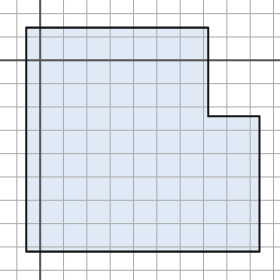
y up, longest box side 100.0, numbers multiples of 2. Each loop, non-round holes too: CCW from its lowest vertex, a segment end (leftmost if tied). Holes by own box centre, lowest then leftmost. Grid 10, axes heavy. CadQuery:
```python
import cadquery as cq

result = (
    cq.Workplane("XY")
    .moveTo(-6.0, -82.0)
    .lineTo(94.0, -82.0)
    .lineTo(94.0, -24.0)
    .lineTo(72.0, -24.0)
    .lineTo(72.0, 14.0)
    .lineTo(-6.0, 14.0)
    .close()
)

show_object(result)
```